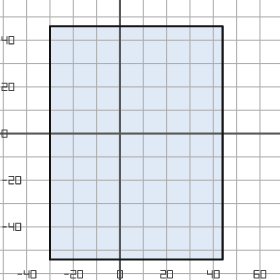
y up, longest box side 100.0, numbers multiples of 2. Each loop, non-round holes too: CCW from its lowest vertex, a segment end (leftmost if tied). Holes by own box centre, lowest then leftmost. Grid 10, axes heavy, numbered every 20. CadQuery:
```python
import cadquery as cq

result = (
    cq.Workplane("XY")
    .moveTo(-30.0, -54.0)
    .lineTo(44.0, -54.0)
    .lineTo(44.0, 46.0)
    .lineTo(-30.0, 46.0)
    .close()
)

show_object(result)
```